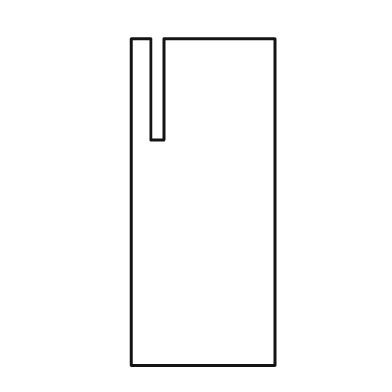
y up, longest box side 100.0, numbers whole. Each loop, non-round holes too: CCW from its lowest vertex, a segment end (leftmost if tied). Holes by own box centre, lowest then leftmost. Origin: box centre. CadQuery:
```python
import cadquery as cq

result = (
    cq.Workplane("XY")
    .moveTo(-22.0, -50.0)
    .lineTo(22.0, -50.0)
    .lineTo(22.0, 50.0)
    .lineTo(-12.0, 50.0)
    .lineTo(-12.0, 19.0)
    .lineTo(-16.0, 19.0)
    .lineTo(-16.0, 50.0)
    .lineTo(-22.0, 50.0)
    .close()
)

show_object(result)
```